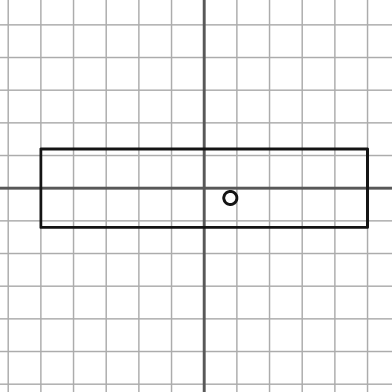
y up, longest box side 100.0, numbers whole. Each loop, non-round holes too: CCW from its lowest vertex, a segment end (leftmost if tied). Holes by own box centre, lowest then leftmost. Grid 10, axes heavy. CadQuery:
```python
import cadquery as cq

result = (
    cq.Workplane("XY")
    .moveTo(-50.0, -12.0)
    .lineTo(50.0, -12.0)
    .lineTo(50.0, 12.0)
    .lineTo(-50.0, 12.0)
    .close()
    .moveTo(8.0, -3.0)
    .circle(2.0)
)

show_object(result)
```